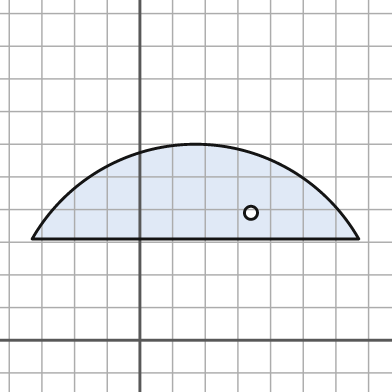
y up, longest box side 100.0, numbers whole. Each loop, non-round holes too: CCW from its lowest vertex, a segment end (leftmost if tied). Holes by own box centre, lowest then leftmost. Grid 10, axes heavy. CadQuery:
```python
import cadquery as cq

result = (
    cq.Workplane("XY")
    .moveTo(-33.0, 31.0)
    .lineTo(67.0, 31.0)
    .threePointArc((17.0, 60.0), (-33.0, 31.0))
    .close()
    .moveTo(34.0, 39.0)
    .circle(2.0)
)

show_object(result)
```